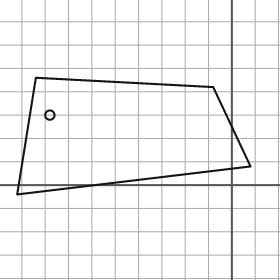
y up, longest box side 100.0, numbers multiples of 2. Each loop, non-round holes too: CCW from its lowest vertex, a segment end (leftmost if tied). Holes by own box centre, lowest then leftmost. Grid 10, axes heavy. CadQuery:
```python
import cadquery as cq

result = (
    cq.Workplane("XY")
    .moveTo(-92.0, -4.0)
    .lineTo(8.0, 8.0)
    .lineTo(-8.0, 42.0)
    .lineTo(-84.0, 46.0)
    .close()
    .moveTo(-78.0, 30.0)
    .circle(2.0)
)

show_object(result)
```